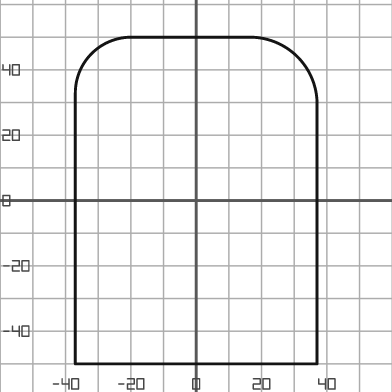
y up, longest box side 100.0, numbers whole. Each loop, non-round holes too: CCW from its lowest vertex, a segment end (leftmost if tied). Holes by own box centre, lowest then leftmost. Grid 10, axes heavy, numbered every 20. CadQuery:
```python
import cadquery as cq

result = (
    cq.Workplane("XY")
    .moveTo(-37.0, -50.0)
    .lineTo(37.0, -50.0)
    .lineTo(37.0, 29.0)
    .threePointArc((31.0, 44.0), (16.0, 50.0))
    .lineTo(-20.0, 50.0)
    .threePointArc((-32.0, 45.0), (-37.0, 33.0))
    .close()
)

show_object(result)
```